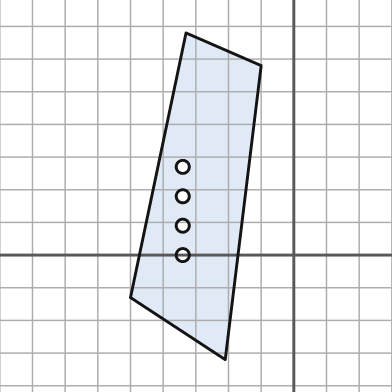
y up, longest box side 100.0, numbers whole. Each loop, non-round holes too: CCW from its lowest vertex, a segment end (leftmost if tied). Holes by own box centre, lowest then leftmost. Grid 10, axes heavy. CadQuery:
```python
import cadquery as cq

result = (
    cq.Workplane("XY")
    .moveTo(-21.0, -32.0)
    .lineTo(-10.0, 58.0)
    .lineTo(-33.0, 68.0)
    .lineTo(-50.0, -13.0)
    .close()
    .moveTo(-34.0, 0.0)
    .circle(2.0)
    .moveTo(-34.0, 9.0)
    .circle(2.0)
    .moveTo(-34.0, 18.0)
    .circle(2.0)
    .moveTo(-34.0, 27.0)
    .circle(2.0)
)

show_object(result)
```